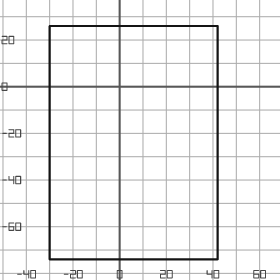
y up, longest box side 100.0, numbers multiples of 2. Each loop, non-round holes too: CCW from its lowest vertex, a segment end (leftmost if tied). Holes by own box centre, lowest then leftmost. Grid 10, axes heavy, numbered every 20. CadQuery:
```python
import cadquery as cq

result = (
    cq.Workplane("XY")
    .moveTo(-30.0, -74.0)
    .lineTo(42.0, -74.0)
    .lineTo(42.0, 26.0)
    .lineTo(-30.0, 26.0)
    .close()
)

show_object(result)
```